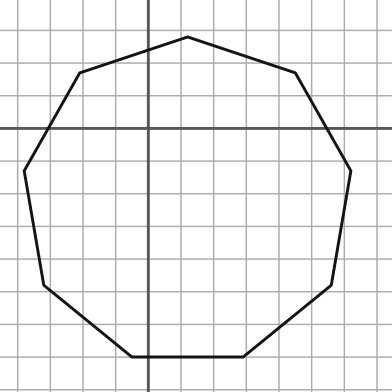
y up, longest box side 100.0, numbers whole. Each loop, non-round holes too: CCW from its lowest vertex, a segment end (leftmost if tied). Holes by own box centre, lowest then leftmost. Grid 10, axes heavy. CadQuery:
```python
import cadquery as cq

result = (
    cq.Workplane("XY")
    .moveTo(-5.0, -70.0)
    .lineTo(29.0, -70.0)
    .lineTo(56.0, -48.0)
    .lineTo(62.0, -13.0)
    .lineTo(45.0, 17.0)
    .lineTo(12.0, 28.0)
    .lineTo(-21.0, 17.0)
    .lineTo(-38.0, -13.0)
    .lineTo(-32.0, -48.0)
    .close()
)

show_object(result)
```